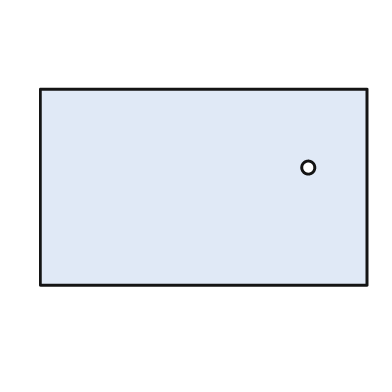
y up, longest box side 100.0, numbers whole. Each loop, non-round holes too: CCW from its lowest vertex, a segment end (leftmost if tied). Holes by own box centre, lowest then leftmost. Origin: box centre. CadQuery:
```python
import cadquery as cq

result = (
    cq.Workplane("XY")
    .moveTo(-50.0, -30.0)
    .lineTo(50.0, -30.0)
    .lineTo(50.0, 30.0)
    .lineTo(-50.0, 30.0)
    .close()
    .moveTo(32.0, 6.0)
    .circle(2.0)
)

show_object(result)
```